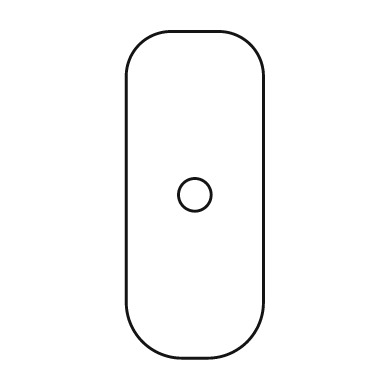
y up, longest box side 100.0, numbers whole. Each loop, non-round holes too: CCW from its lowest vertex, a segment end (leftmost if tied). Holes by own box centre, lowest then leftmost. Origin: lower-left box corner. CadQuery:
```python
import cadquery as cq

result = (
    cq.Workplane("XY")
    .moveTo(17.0, 0.0)
    .lineTo(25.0, 0.0)
    .threePointArc((37.0, 5.0), (42.0, 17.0))
    .lineTo(42.0, 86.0)
    .threePointArc((38.0, 96.0), (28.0, 100.0))
    .lineTo(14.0, 100.0)
    .threePointArc((4.0, 96.0), (0.0, 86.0))
    .lineTo(0.0, 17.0)
    .threePointArc((5.0, 5.0), (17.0, 0.0))
    .close()
    .moveTo(21.0, 50.0)
    .circle(5.0)
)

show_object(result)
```